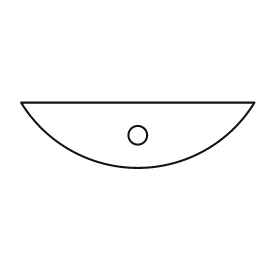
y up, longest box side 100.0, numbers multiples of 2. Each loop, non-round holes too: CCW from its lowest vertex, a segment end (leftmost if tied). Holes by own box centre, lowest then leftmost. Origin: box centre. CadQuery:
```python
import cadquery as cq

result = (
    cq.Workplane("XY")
    .moveTo(-50.0, 14.0)
    .threePointArc((0.0, -14.0), (50.0, 14.0))
    .close()
    .moveTo(0.0, 0.0)
    .circle(4.0)
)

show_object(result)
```